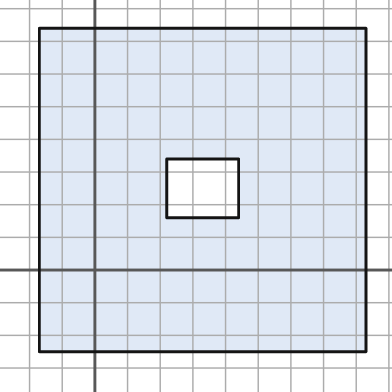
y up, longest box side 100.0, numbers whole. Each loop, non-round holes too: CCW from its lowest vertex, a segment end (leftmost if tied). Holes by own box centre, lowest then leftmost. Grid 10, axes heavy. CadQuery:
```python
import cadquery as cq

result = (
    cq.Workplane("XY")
    .moveTo(-17.0, -25.0)
    .lineTo(83.0, -25.0)
    .lineTo(83.0, 74.0)
    .lineTo(-17.0, 74.0)
    .close()
    .moveTo(22.0, 16.0)
    .lineTo(44.0, 16.0)
    .lineTo(44.0, 34.0)
    .lineTo(22.0, 34.0)
    .close()
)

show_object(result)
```